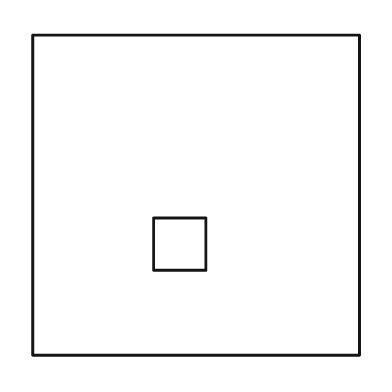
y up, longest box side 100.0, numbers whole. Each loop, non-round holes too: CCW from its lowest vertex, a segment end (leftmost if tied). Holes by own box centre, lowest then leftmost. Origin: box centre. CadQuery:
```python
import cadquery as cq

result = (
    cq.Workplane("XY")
    .moveTo(-50.0, -49.0)
    .lineTo(50.0, -49.0)
    .lineTo(50.0, 49.0)
    .lineTo(-50.0, 49.0)
    .close()
    .moveTo(-13.0, -23.0)
    .lineTo(3.0, -23.0)
    .lineTo(3.0, -7.0)
    .lineTo(-13.0, -7.0)
    .close()
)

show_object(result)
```